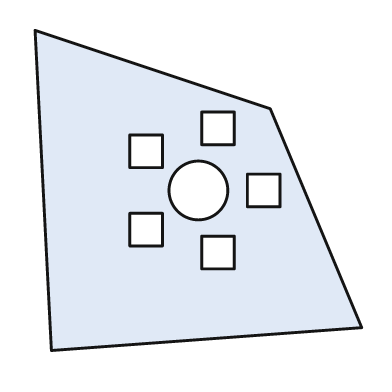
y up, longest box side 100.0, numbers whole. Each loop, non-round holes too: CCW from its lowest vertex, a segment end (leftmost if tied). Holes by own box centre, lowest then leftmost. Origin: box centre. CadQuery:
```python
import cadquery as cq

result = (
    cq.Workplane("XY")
    .moveTo(-45.0, -49.0)
    .lineTo(50.0, -42.0)
    .lineTo(22.0, 25.0)
    .lineTo(-50.0, 49.0)
    .close()
    .moveTo(1.0, -24.0)
    .lineTo(11.0, -24.0)
    .lineTo(11.0, -14.0)
    .lineTo(1.0, -14.0)
    .close()
    .moveTo(-21.0, -17.0)
    .lineTo(-11.0, -17.0)
    .lineTo(-11.0, -7.0)
    .lineTo(-21.0, -7.0)
    .close()
    .moveTo(0.0, 0.0)
    .circle(9.0)
    .moveTo(15.0, -5.0)
    .lineTo(25.0, -5.0)
    .lineTo(25.0, 5.0)
    .lineTo(15.0, 5.0)
    .close()
    .moveTo(-21.0, 7.0)
    .lineTo(-11.0, 7.0)
    .lineTo(-11.0, 17.0)
    .lineTo(-21.0, 17.0)
    .close()
    .moveTo(1.0, 14.0)
    .lineTo(11.0, 14.0)
    .lineTo(11.0, 24.0)
    .lineTo(1.0, 24.0)
    .close()
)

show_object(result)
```